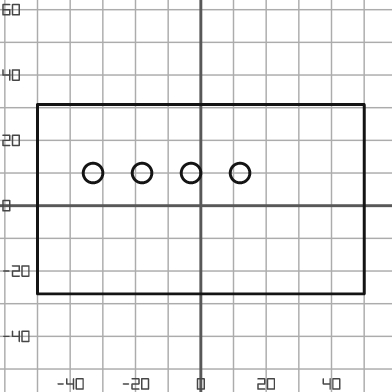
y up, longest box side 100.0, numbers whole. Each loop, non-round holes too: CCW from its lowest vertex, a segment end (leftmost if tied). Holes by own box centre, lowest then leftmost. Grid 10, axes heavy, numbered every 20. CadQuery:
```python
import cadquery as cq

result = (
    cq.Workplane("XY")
    .moveTo(-50.0, -27.0)
    .lineTo(50.0, -27.0)
    .lineTo(50.0, 31.0)
    .lineTo(-50.0, 31.0)
    .close()
    .moveTo(-33.0, 10.0)
    .circle(3.0)
    .moveTo(-18.0, 10.0)
    .circle(3.0)
    .moveTo(-3.0, 10.0)
    .circle(3.0)
    .moveTo(12.0, 10.0)
    .circle(3.0)
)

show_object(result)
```